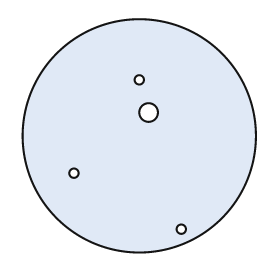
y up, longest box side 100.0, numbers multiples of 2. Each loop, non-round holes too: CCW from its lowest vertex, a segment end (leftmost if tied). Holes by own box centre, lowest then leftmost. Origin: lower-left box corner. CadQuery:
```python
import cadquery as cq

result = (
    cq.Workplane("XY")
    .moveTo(50.0, 50.0)
    .circle(50.0)
    .moveTo(68.0, 10.0)
    .circle(2.0)
    .moveTo(22.0, 34.0)
    .circle(2.0)
    .moveTo(54.0, 60.0)
    .circle(4.0)
    .moveTo(50.0, 74.0)
    .circle(2.0)
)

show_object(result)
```